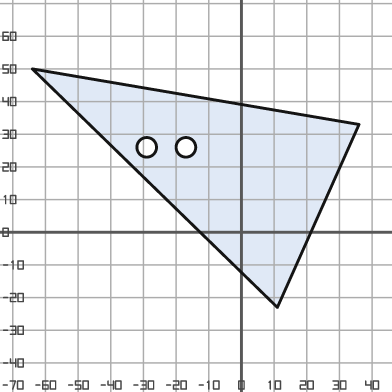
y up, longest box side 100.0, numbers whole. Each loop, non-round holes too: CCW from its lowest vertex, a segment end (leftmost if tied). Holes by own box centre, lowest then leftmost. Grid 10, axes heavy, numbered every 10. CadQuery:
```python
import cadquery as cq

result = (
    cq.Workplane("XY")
    .moveTo(11.0, -23.0)
    .lineTo(36.0, 33.0)
    .lineTo(-64.0, 50.0)
    .close()
    .moveTo(-29.0, 26.0)
    .circle(3.0)
    .moveTo(-17.0, 26.0)
    .circle(3.0)
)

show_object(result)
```